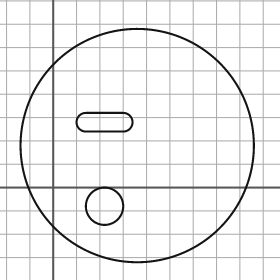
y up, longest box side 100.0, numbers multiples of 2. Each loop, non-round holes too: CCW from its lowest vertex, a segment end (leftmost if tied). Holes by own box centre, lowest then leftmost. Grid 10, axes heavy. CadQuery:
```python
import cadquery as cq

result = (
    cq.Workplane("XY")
    .moveTo(36.0, 18.0)
    .circle(50.0)
    .moveTo(22.0, -8.0)
    .circle(8.0)
    .moveTo(14.0, 24.0)
    .lineTo(30.0, 24.0)
    .threePointArc((34.0, 28.0), (30.0, 32.0))
    .lineTo(14.0, 32.0)
    .threePointArc((10.0, 28.0), (14.0, 24.0))
    .close()
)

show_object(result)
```